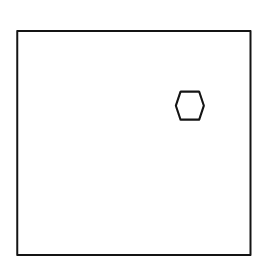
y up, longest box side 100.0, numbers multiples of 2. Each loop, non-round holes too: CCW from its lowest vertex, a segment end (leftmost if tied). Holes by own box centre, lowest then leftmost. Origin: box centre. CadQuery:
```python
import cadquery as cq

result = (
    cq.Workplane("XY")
    .moveTo(-50.0, -48.0)
    .lineTo(50.0, -48.0)
    .lineTo(50.0, 48.0)
    .lineTo(-50.0, 48.0)
    .close()
    .moveTo(20.0, 10.0)
    .lineTo(28.0, 10.0)
    .lineTo(30.0, 16.0)
    .lineTo(28.0, 22.0)
    .lineTo(20.0, 22.0)
    .lineTo(18.0, 16.0)
    .close()
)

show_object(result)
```